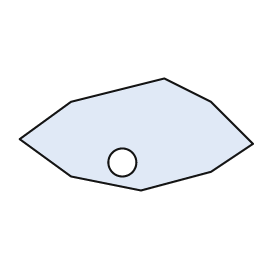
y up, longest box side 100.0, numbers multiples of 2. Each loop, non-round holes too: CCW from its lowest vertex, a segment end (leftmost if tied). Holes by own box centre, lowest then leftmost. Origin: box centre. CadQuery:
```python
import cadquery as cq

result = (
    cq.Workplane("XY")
    .moveTo(2.0, -24.0)
    .lineTo(32.0, -16.0)
    .lineTo(50.0, -4.0)
    .lineTo(32.0, 14.0)
    .lineTo(12.0, 24.0)
    .lineTo(-28.0, 14.0)
    .lineTo(-50.0, -2.0)
    .lineTo(-28.0, -18.0)
    .close()
    .moveTo(-6.0, -12.0)
    .circle(6.0)
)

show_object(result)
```